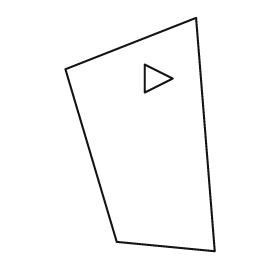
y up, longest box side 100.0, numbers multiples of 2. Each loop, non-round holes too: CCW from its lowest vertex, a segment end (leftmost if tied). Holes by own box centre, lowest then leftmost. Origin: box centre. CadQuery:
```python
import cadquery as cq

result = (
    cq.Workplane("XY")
    .moveTo(32.0, -50.0)
    .lineTo(24.0, 50.0)
    .lineTo(-32.0, 28.0)
    .lineTo(-10.0, -46.0)
    .close()
    .moveTo(2.0, 18.0)
    .lineTo(14.0, 24.0)
    .lineTo(2.0, 30.0)
    .close()
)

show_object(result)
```